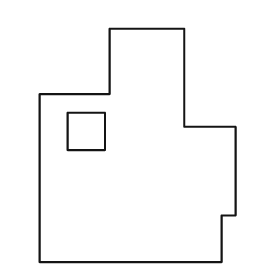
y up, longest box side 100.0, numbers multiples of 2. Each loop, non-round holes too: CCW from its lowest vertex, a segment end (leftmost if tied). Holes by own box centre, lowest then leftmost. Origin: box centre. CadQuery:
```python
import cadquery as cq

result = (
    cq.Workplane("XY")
    .moveTo(-42.0, -50.0)
    .lineTo(36.0, -50.0)
    .lineTo(36.0, -30.0)
    .lineTo(42.0, -30.0)
    .lineTo(42.0, 8.0)
    .lineTo(20.0, 8.0)
    .lineTo(20.0, 50.0)
    .lineTo(-12.0, 50.0)
    .lineTo(-12.0, 22.0)
    .lineTo(-42.0, 22.0)
    .close()
    .moveTo(-30.0, -2.0)
    .lineTo(-14.0, -2.0)
    .lineTo(-14.0, 14.0)
    .lineTo(-30.0, 14.0)
    .close()
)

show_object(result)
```